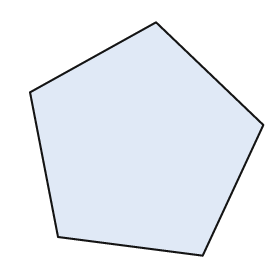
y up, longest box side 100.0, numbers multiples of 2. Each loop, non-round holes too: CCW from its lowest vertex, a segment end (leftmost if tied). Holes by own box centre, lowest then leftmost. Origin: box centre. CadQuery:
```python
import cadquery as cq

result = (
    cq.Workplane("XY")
    .moveTo(24.0, -50.0)
    .lineTo(50.0, 6.0)
    .lineTo(4.0, 50.0)
    .lineTo(-50.0, 20.0)
    .lineTo(-38.0, -42.0)
    .close()
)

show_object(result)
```